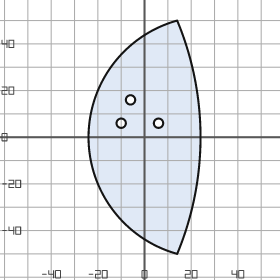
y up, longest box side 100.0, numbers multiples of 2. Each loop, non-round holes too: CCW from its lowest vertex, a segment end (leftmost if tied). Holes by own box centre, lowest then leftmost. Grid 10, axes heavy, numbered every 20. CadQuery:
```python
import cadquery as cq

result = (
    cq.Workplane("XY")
    .moveTo(14.0, -50.0)
    .threePointArc((24.0, 0.0), (14.0, 50.0))
    .threePointArc((-24.0, 0.0), (14.0, -50.0))
    .close()
    .moveTo(-10.0, 6.0)
    .circle(2.0)
    .moveTo(6.0, 6.0)
    .circle(2.0)
    .moveTo(-6.0, 16.0)
    .circle(2.0)
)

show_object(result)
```